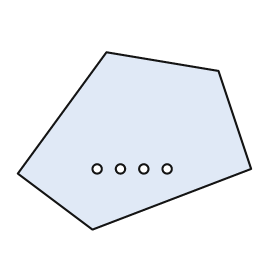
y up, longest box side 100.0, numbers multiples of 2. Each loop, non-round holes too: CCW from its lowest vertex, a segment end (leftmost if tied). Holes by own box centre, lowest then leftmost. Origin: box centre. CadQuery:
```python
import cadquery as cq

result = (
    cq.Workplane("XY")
    .moveTo(-18.0, -38.0)
    .lineTo(50.0, -12.0)
    .lineTo(36.0, 30.0)
    .lineTo(-12.0, 38.0)
    .lineTo(-50.0, -14.0)
    .close()
    .moveTo(-16.0, -12.0)
    .circle(2.0)
    .moveTo(-6.0, -12.0)
    .circle(2.0)
    .moveTo(4.0, -12.0)
    .circle(2.0)
    .moveTo(14.0, -12.0)
    .circle(2.0)
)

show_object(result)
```